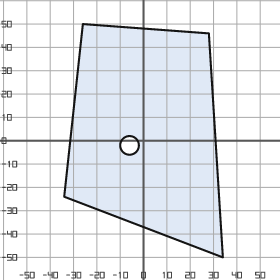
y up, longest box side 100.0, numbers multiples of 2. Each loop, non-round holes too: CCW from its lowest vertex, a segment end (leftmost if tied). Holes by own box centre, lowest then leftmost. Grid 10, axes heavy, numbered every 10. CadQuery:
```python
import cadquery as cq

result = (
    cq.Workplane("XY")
    .moveTo(34.0, -50.0)
    .lineTo(28.0, 46.0)
    .lineTo(-26.0, 50.0)
    .lineTo(-34.0, -24.0)
    .close()
    .moveTo(-6.0, -2.0)
    .circle(4.0)
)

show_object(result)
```